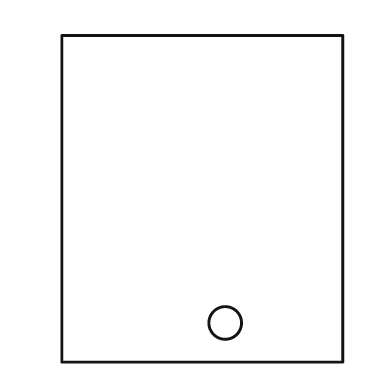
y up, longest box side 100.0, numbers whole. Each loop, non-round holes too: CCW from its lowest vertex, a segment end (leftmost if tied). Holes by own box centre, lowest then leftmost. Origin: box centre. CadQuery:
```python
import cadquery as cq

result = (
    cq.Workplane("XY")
    .moveTo(-43.0, -50.0)
    .lineTo(43.0, -50.0)
    .lineTo(43.0, 50.0)
    .lineTo(-43.0, 50.0)
    .close()
    .moveTo(7.0, -38.0)
    .circle(5.0)
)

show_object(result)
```